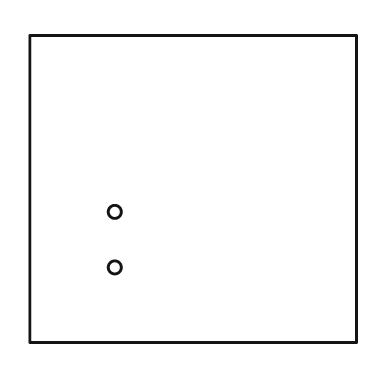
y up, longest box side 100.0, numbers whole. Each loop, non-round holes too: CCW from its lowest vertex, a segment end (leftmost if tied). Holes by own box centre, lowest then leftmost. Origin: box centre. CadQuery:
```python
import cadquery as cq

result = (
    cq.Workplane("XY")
    .moveTo(-50.0, -47.0)
    .lineTo(50.0, -47.0)
    .lineTo(50.0, 47.0)
    .lineTo(-50.0, 47.0)
    .close()
    .moveTo(-24.0, -24.0)
    .circle(2.0)
    .moveTo(-24.0, -7.0)
    .circle(2.0)
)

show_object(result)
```